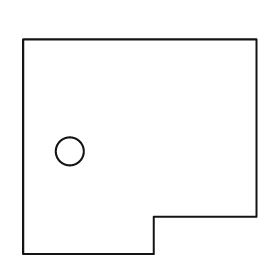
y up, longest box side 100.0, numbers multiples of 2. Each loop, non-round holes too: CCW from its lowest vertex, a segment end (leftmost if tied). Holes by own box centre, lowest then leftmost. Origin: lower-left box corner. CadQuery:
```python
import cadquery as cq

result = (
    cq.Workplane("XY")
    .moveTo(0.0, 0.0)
    .lineTo(56.0, 0.0)
    .lineTo(56.0, 16.0)
    .lineTo(100.0, 16.0)
    .lineTo(100.0, 92.0)
    .lineTo(0.0, 92.0)
    .close()
    .moveTo(20.0, 44.0)
    .circle(6.0)
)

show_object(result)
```